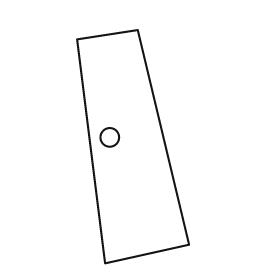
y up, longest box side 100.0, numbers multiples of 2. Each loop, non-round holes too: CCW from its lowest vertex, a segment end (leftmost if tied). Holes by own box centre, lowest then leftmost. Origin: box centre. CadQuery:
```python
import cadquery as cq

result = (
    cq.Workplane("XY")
    .moveTo(-12.0, -50.0)
    .lineTo(24.0, -42.0)
    .lineTo(2.0, 50.0)
    .lineTo(-24.0, 46.0)
    .close()
    .moveTo(-10.0, 4.0)
    .circle(4.0)
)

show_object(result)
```